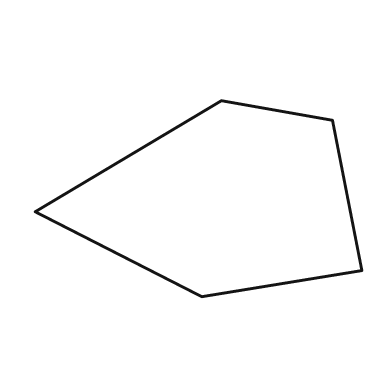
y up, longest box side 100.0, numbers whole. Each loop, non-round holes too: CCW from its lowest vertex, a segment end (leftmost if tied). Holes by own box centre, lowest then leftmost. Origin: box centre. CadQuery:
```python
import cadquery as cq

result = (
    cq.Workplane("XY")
    .moveTo(1.0, -30.0)
    .lineTo(50.0, -22.0)
    .lineTo(41.0, 24.0)
    .lineTo(7.0, 30.0)
    .lineTo(-50.0, -4.0)
    .close()
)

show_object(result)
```